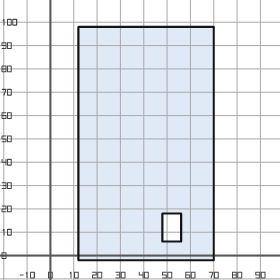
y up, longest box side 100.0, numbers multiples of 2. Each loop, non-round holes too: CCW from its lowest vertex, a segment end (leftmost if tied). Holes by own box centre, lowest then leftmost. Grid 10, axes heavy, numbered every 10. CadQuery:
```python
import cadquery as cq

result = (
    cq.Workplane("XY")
    .moveTo(12.0, -2.0)
    .lineTo(70.0, -2.0)
    .lineTo(70.0, 98.0)
    .lineTo(12.0, 98.0)
    .close()
    .moveTo(48.0, 6.0)
    .lineTo(56.0, 6.0)
    .lineTo(56.0, 18.0)
    .lineTo(48.0, 18.0)
    .close()
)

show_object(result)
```